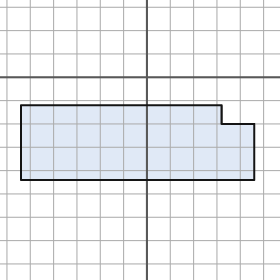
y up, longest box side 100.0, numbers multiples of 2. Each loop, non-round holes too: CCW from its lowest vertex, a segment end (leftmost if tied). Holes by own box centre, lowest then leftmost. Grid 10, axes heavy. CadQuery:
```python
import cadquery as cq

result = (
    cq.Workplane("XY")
    .moveTo(-54.0, -44.0)
    .lineTo(46.0, -44.0)
    .lineTo(46.0, -20.0)
    .lineTo(32.0, -20.0)
    .lineTo(32.0, -12.0)
    .lineTo(-54.0, -12.0)
    .close()
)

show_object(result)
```